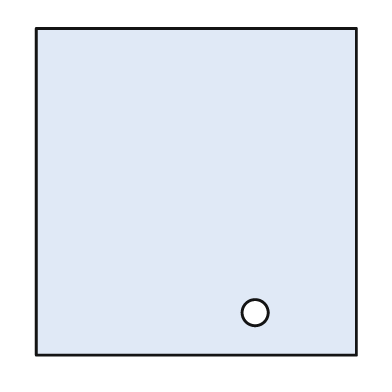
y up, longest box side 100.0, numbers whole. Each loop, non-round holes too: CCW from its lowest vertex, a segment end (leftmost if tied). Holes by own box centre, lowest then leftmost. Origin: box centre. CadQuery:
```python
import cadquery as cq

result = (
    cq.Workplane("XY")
    .moveTo(-49.0, -50.0)
    .lineTo(49.0, -50.0)
    .lineTo(49.0, 50.0)
    .lineTo(-49.0, 50.0)
    .close()
    .moveTo(18.0, -37.0)
    .circle(4.0)
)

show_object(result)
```